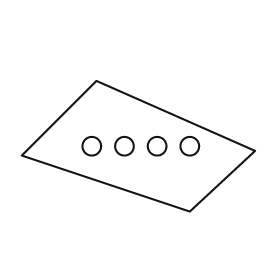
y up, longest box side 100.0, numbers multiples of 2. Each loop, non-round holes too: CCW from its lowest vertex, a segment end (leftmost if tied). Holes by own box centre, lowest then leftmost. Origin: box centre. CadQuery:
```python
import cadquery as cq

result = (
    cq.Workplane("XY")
    .moveTo(22.0, -28.0)
    .lineTo(50.0, -2.0)
    .lineTo(-18.0, 28.0)
    .lineTo(-50.0, -4.0)
    .close()
    .moveTo(-20.0, 0.0)
    .circle(4.0)
    .moveTo(-6.0, 0.0)
    .circle(4.0)
    .moveTo(8.0, 0.0)
    .circle(4.0)
    .moveTo(22.0, 0.0)
    .circle(4.0)
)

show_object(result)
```